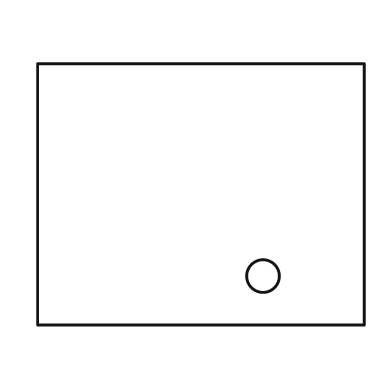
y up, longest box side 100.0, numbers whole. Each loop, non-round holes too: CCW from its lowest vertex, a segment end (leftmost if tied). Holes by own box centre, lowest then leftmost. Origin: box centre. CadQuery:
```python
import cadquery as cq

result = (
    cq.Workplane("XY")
    .moveTo(-50.0, -40.0)
    .lineTo(50.0, -40.0)
    .lineTo(50.0, 40.0)
    .lineTo(-50.0, 40.0)
    .close()
    .moveTo(19.0, -25.0)
    .circle(5.0)
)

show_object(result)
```